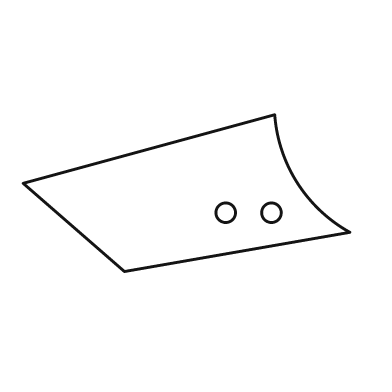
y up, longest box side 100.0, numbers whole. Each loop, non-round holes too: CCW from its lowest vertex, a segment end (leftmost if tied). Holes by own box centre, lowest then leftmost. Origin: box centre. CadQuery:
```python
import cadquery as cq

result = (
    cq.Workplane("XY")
    .moveTo(-19.0, -24.0)
    .lineTo(50.0, -12.0)
    .threePointArc((34.0, 3.0), (27.0, 24.0))
    .lineTo(-50.0, 3.0)
    .close()
    .moveTo(12.0, -6.0)
    .circle(3.0)
    .moveTo(26.0, -6.0)
    .circle(3.0)
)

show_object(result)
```